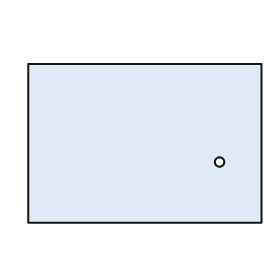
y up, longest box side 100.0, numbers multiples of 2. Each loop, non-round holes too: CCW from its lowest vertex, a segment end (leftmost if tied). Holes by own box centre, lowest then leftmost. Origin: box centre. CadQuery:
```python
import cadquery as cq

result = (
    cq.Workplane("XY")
    .moveTo(-50.0, -34.0)
    .lineTo(50.0, -34.0)
    .lineTo(50.0, 34.0)
    .lineTo(-50.0, 34.0)
    .close()
    .moveTo(32.0, -8.0)
    .circle(2.0)
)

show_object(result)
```